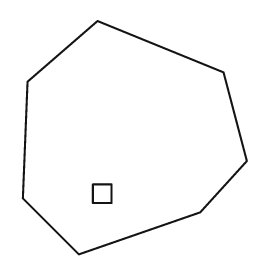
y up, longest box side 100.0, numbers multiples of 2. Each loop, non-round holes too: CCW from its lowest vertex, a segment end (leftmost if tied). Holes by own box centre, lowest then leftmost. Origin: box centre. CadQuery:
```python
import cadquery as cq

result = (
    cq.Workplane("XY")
    .moveTo(-24.0, -50.0)
    .lineTo(28.0, -32.0)
    .lineTo(48.0, -10.0)
    .lineTo(38.0, 28.0)
    .lineTo(-16.0, 50.0)
    .lineTo(-46.0, 24.0)
    .lineTo(-48.0, -26.0)
    .close()
    .moveTo(-18.0, -28.0)
    .lineTo(-10.0, -28.0)
    .lineTo(-10.0, -20.0)
    .lineTo(-18.0, -20.0)
    .close()
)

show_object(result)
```